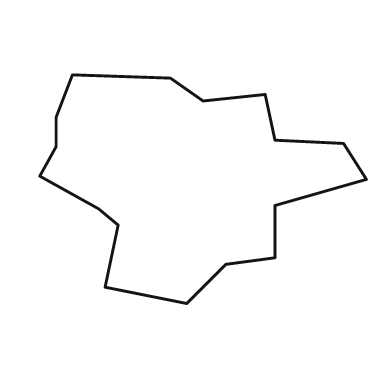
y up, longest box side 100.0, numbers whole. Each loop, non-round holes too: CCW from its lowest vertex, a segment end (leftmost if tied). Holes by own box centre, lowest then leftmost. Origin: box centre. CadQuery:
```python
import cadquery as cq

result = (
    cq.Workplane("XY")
    .moveTo(-5.0, -35.0)
    .lineTo(7.0, -23.0)
    .lineTo(22.0, -21.0)
    .lineTo(22.0, -5.0)
    .lineTo(50.0, 3.0)
    .lineTo(43.0, 14.0)
    .lineTo(22.0, 15.0)
    .lineTo(19.0, 29.0)
    .lineTo(0.0, 27.0)
    .lineTo(-10.0, 34.0)
    .lineTo(-40.0, 35.0)
    .lineTo(-45.0, 22.0)
    .lineTo(-45.0, 13.0)
    .lineTo(-50.0, 4.0)
    .lineTo(-32.0, -6.0)
    .lineTo(-26.0, -11.0)
    .lineTo(-30.0, -30.0)
    .close()
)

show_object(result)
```